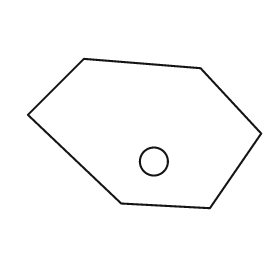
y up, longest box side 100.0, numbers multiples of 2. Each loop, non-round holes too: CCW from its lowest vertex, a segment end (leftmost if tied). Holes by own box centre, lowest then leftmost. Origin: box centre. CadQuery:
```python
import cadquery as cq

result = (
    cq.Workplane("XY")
    .moveTo(28.0, -32.0)
    .lineTo(50.0, 0.0)
    .lineTo(24.0, 28.0)
    .lineTo(-26.0, 32.0)
    .lineTo(-50.0, 8.0)
    .lineTo(-10.0, -30.0)
    .close()
    .moveTo(4.0, -12.0)
    .circle(6.0)
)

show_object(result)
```